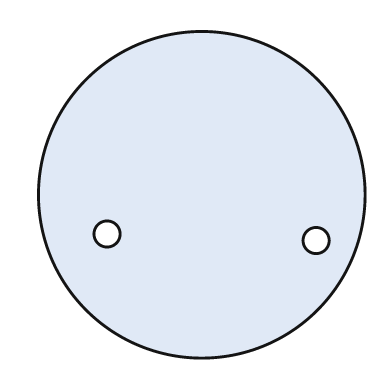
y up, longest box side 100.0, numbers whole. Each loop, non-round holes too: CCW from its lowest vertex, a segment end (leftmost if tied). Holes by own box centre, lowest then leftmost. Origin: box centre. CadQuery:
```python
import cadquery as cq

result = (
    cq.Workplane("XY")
    .moveTo(0.0, 0.0)
    .circle(50.0)
    .moveTo(35.0, -14.0)
    .circle(4.0)
    .moveTo(-29.0, -12.0)
    .circle(4.0)
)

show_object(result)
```